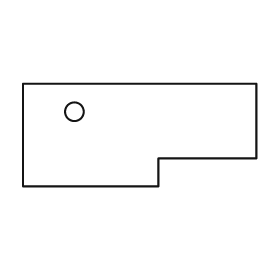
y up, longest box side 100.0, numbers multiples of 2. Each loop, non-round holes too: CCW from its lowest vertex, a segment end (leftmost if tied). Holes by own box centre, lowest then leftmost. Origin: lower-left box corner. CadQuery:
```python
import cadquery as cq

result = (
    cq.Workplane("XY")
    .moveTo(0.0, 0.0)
    .lineTo(58.0, 0.0)
    .lineTo(58.0, 12.0)
    .lineTo(100.0, 12.0)
    .lineTo(100.0, 44.0)
    .lineTo(0.0, 44.0)
    .close()
    .moveTo(22.0, 32.0)
    .circle(4.0)
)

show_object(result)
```